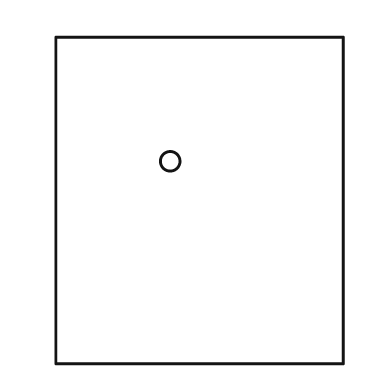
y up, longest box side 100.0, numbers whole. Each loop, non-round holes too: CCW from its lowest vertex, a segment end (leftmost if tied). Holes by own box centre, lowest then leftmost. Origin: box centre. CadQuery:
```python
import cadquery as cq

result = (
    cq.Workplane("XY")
    .moveTo(-44.0, -50.0)
    .lineTo(44.0, -50.0)
    .lineTo(44.0, 50.0)
    .lineTo(-44.0, 50.0)
    .close()
    .moveTo(-9.0, 12.0)
    .circle(3.0)
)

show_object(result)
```